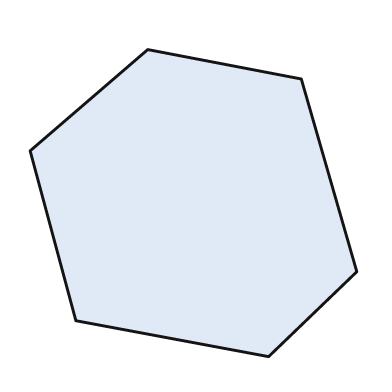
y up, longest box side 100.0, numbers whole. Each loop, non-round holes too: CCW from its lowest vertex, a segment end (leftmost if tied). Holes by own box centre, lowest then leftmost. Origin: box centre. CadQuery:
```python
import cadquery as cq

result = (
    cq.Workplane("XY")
    .moveTo(23.0, -47.0)
    .lineTo(50.0, -21.0)
    .lineTo(33.0, 38.0)
    .lineTo(-14.0, 47.0)
    .lineTo(-50.0, 16.0)
    .lineTo(-36.0, -36.0)
    .close()
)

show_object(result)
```